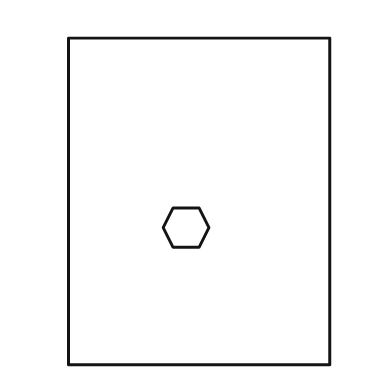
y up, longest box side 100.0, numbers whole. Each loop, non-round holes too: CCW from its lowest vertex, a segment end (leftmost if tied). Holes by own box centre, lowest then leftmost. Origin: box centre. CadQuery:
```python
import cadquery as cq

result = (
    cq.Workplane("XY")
    .moveTo(-40.0, -50.0)
    .lineTo(40.0, -50.0)
    .lineTo(40.0, 50.0)
    .lineTo(-40.0, 50.0)
    .close()
    .moveTo(-8.0, -14.0)
    .lineTo(0.0, -14.0)
    .lineTo(3.0, -8.0)
    .lineTo(0.0, -2.0)
    .lineTo(-8.0, -2.0)
    .lineTo(-11.0, -8.0)
    .close()
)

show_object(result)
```